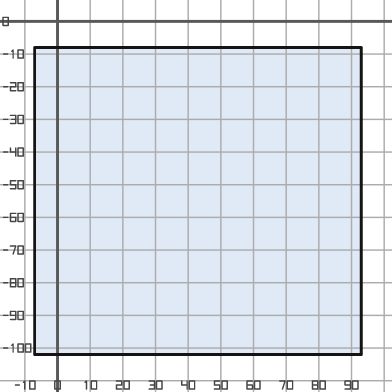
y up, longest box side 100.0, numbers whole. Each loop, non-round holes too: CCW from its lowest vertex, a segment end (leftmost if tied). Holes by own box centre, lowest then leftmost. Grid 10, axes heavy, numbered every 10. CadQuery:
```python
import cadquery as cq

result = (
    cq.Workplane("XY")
    .moveTo(-7.0, -102.0)
    .lineTo(93.0, -102.0)
    .lineTo(93.0, -8.0)
    .lineTo(-7.0, -8.0)
    .close()
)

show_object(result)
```